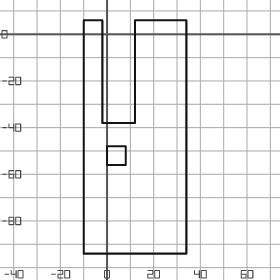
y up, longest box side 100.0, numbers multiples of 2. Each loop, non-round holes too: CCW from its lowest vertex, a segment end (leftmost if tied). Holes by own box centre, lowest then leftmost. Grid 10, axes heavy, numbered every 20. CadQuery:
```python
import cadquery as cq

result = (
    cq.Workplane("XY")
    .moveTo(-10.0, -94.0)
    .lineTo(34.0, -94.0)
    .lineTo(34.0, 6.0)
    .lineTo(12.0, 6.0)
    .lineTo(12.0, -38.0)
    .lineTo(-2.0, -38.0)
    .lineTo(-2.0, 6.0)
    .lineTo(-10.0, 6.0)
    .close()
    .moveTo(0.0, -56.0)
    .lineTo(8.0, -56.0)
    .lineTo(8.0, -48.0)
    .lineTo(0.0, -48.0)
    .close()
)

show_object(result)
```